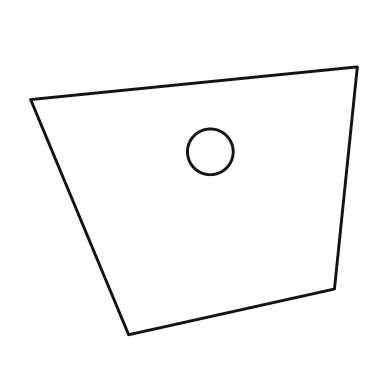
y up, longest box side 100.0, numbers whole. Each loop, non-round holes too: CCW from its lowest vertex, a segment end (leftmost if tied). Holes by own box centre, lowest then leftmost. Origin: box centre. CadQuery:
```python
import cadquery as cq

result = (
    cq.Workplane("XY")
    .moveTo(-20.0, -41.0)
    .lineTo(43.0, -27.0)
    .lineTo(50.0, 41.0)
    .lineTo(-50.0, 31.0)
    .close()
    .moveTo(5.0, 15.0)
    .circle(7.0)
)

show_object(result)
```